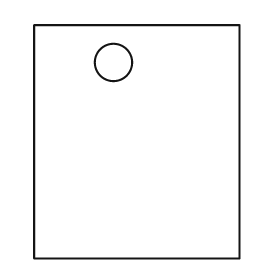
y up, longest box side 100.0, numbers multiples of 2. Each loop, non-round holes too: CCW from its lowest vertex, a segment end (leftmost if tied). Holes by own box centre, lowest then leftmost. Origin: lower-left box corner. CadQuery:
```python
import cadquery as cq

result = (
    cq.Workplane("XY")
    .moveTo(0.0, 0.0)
    .lineTo(88.0, 0.0)
    .lineTo(88.0, 100.0)
    .lineTo(0.0, 100.0)
    .close()
    .moveTo(34.0, 84.0)
    .circle(8.0)
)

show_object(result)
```